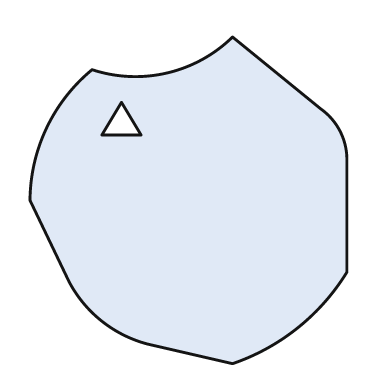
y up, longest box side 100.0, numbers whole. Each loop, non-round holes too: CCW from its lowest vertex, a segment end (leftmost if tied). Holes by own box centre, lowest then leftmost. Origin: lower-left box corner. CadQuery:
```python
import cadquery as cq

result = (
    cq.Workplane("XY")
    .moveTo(62.0, 0.0)
    .threePointArc((82.0, 11.0), (97.0, 28.0))
    .lineTo(97.0, 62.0)
    .threePointArc((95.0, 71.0), (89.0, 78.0))
    .lineTo(62.0, 100.0)
    .threePointArc((42.0, 89.0), (19.0, 90.0))
    .threePointArc((5.0, 72.0), (0.0, 50.0))
    .lineTo(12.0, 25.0)
    .threePointArc((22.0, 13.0), (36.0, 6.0))
    .close()
    .moveTo(22.0, 70.0)
    .lineTo(34.0, 70.0)
    .lineTo(28.0, 80.0)
    .close()
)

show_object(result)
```